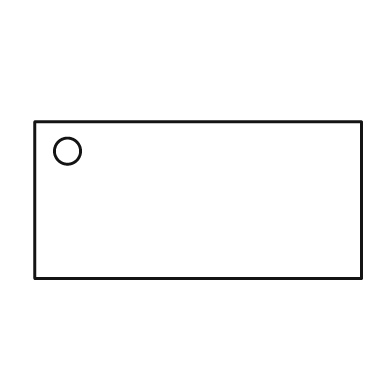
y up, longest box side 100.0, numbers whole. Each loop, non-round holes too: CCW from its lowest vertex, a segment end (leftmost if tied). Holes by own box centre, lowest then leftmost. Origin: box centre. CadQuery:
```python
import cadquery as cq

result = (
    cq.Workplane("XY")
    .moveTo(-50.0, -24.0)
    .lineTo(50.0, -24.0)
    .lineTo(50.0, 24.0)
    .lineTo(-50.0, 24.0)
    .close()
    .moveTo(-40.0, 15.0)
    .circle(4.0)
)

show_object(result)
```